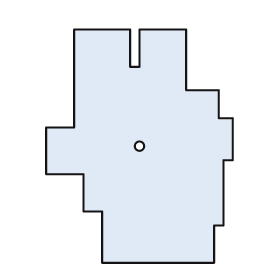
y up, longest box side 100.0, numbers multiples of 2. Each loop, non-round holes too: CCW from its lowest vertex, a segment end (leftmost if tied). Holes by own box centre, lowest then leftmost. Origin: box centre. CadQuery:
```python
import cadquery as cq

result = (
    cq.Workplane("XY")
    .moveTo(-16.0, -50.0)
    .lineTo(32.0, -50.0)
    .lineTo(32.0, -34.0)
    .lineTo(36.0, -34.0)
    .lineTo(36.0, -6.0)
    .lineTo(40.0, -6.0)
    .lineTo(40.0, 12.0)
    .lineTo(34.0, 12.0)
    .lineTo(34.0, 24.0)
    .lineTo(20.0, 24.0)
    .lineTo(20.0, 50.0)
    .lineTo(0.0, 50.0)
    .lineTo(0.0, 34.0)
    .lineTo(-4.0, 34.0)
    .lineTo(-4.0, 50.0)
    .lineTo(-28.0, 50.0)
    .lineTo(-28.0, 8.0)
    .lineTo(-40.0, 8.0)
    .lineTo(-40.0, -12.0)
    .lineTo(-24.0, -12.0)
    .lineTo(-24.0, -28.0)
    .lineTo(-16.0, -28.0)
    .close()
    .moveTo(0.0, 0.0)
    .circle(2.0)
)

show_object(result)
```